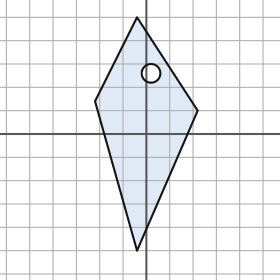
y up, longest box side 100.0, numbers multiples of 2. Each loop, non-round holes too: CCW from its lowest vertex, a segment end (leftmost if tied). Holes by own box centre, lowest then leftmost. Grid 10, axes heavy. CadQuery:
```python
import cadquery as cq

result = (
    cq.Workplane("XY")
    .moveTo(-4.0, -50.0)
    .lineTo(22.0, 10.0)
    .lineTo(-4.0, 50.0)
    .lineTo(-22.0, 14.0)
    .close()
    .moveTo(2.0, 26.0)
    .circle(4.0)
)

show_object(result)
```